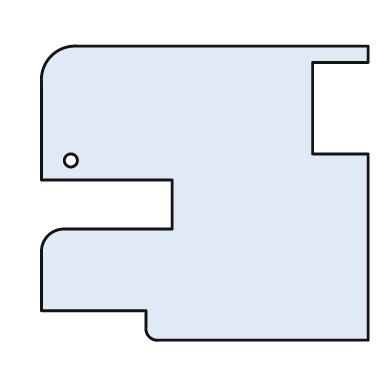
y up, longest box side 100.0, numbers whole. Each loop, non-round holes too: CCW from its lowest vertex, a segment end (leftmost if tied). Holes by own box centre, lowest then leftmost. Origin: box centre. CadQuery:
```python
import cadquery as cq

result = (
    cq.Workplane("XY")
    .moveTo(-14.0, -45.0)
    .lineTo(50.0, -45.0)
    .lineTo(50.0, 12.0)
    .lineTo(33.0, 12.0)
    .lineTo(33.0, 40.0)
    .lineTo(50.0, 40.0)
    .lineTo(50.0, 45.0)
    .lineTo(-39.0, 45.0)
    .threePointArc((-47.0, 42.0), (-50.0, 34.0))
    .lineTo(-50.0, 4.0)
    .lineTo(-10.0, 4.0)
    .lineTo(-10.0, -11.0)
    .lineTo(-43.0, -11.0)
    .threePointArc((-48.0, -13.0), (-50.0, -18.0))
    .lineTo(-50.0, -36.0)
    .lineTo(-18.0, -36.0)
    .lineTo(-18.0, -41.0)
    .threePointArc((-17.0, -44.0), (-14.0, -45.0))
    .close()
    .moveTo(-41.0, 10.0)
    .circle(2.0)
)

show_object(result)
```